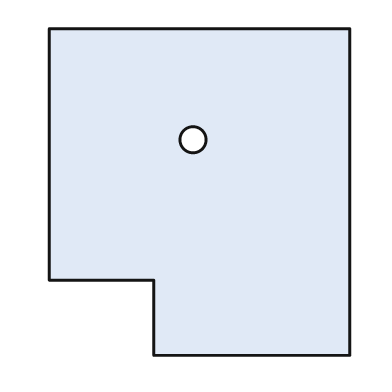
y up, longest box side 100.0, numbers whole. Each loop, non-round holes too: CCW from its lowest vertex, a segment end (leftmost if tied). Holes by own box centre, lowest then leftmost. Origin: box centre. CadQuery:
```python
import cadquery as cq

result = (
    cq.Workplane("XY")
    .moveTo(-14.0, -50.0)
    .lineTo(46.0, -50.0)
    .lineTo(46.0, 50.0)
    .lineTo(-46.0, 50.0)
    .lineTo(-46.0, -27.0)
    .lineTo(-14.0, -27.0)
    .close()
    .moveTo(-2.0, 16.0)
    .circle(4.0)
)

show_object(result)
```